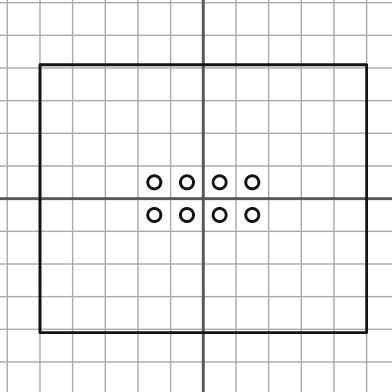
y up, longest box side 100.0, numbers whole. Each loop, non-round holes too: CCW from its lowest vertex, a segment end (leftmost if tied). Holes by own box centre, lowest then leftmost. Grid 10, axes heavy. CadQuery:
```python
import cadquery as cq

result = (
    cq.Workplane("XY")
    .moveTo(-50.0, -41.0)
    .lineTo(50.0, -41.0)
    .lineTo(50.0, 41.0)
    .lineTo(-50.0, 41.0)
    .close()
    .moveTo(-15.0, -5.0)
    .circle(2.0)
    .moveTo(-5.0, -5.0)
    .circle(2.0)
    .moveTo(5.0, -5.0)
    .circle(2.0)
    .moveTo(15.0, -5.0)
    .circle(2.0)
    .moveTo(-15.0, 5.0)
    .circle(2.0)
    .moveTo(-5.0, 5.0)
    .circle(2.0)
    .moveTo(5.0, 5.0)
    .circle(2.0)
    .moveTo(15.0, 5.0)
    .circle(2.0)
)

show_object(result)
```